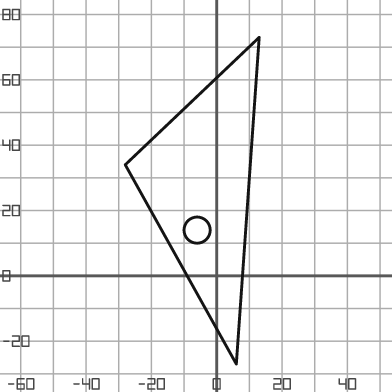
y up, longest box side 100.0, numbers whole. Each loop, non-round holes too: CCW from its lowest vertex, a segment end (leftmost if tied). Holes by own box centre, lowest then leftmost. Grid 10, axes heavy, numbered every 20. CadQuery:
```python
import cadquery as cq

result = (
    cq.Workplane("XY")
    .moveTo(6.0, -27.0)
    .lineTo(13.0, 73.0)
    .lineTo(-28.0, 34.0)
    .close()
    .moveTo(-6.0, 14.0)
    .circle(4.0)
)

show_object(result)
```